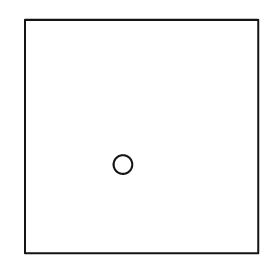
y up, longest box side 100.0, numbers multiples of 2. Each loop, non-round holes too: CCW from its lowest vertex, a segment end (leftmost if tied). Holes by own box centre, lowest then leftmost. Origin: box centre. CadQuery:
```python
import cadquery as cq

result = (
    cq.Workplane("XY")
    .moveTo(-50.0, -50.0)
    .lineTo(50.0, -50.0)
    .lineTo(50.0, 50.0)
    .lineTo(-50.0, 50.0)
    .close()
    .moveTo(-8.0, -12.0)
    .circle(4.0)
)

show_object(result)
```